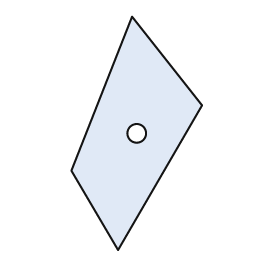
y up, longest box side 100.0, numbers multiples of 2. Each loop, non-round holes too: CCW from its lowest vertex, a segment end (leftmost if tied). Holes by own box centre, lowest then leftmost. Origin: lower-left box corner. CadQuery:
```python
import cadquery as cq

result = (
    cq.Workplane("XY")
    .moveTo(20.0, 0.0)
    .lineTo(56.0, 62.0)
    .lineTo(26.0, 100.0)
    .lineTo(0.0, 34.0)
    .close()
    .moveTo(28.0, 50.0)
    .circle(4.0)
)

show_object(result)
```